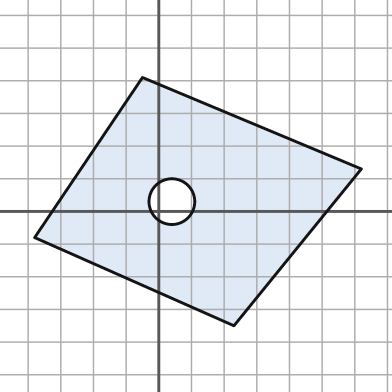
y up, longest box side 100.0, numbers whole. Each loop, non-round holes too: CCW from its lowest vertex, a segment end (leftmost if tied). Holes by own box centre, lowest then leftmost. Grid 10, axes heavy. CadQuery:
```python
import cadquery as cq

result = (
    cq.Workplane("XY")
    .moveTo(23.0, -35.0)
    .lineTo(62.0, 13.0)
    .lineTo(-5.0, 41.0)
    .lineTo(-38.0, -8.0)
    .close()
    .moveTo(4.0, 3.0)
    .circle(7.0)
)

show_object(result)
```